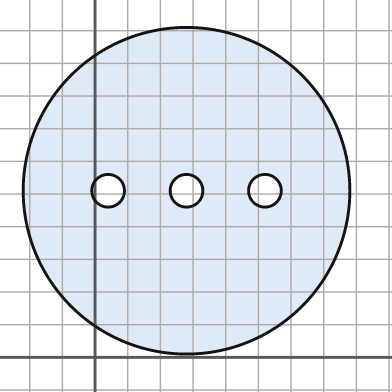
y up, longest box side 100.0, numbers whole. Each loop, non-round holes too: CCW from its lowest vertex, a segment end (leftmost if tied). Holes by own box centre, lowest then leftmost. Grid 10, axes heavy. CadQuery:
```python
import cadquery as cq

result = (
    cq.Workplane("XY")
    .moveTo(28.0, 51.0)
    .circle(50.0)
    .moveTo(4.0, 51.0)
    .circle(5.0)
    .moveTo(28.0, 51.0)
    .circle(5.0)
    .moveTo(52.0, 51.0)
    .circle(5.0)
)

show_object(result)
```